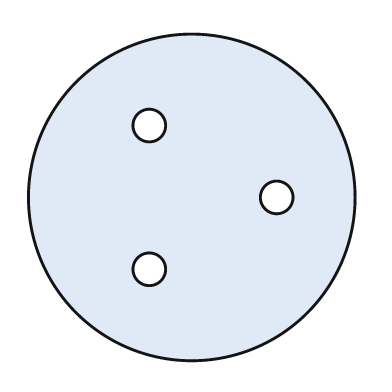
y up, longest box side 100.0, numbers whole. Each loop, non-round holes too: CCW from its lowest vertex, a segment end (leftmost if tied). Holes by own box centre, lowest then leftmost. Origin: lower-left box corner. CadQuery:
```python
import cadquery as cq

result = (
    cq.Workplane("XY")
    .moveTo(50.0, 50.0)
    .circle(50.0)
    .moveTo(37.0, 28.0)
    .circle(5.0)
    .moveTo(76.0, 50.0)
    .circle(5.0)
    .moveTo(37.0, 72.0)
    .circle(5.0)
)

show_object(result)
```